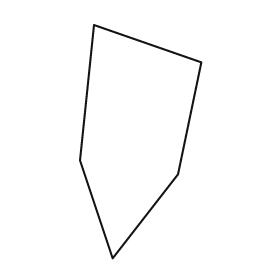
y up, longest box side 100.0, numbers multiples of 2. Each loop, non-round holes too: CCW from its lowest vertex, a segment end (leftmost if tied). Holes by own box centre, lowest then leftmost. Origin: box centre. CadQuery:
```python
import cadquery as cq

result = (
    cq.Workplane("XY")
    .moveTo(-12.0, -50.0)
    .lineTo(16.0, -14.0)
    .lineTo(26.0, 34.0)
    .lineTo(-20.0, 50.0)
    .lineTo(-26.0, -8.0)
    .close()
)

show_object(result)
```